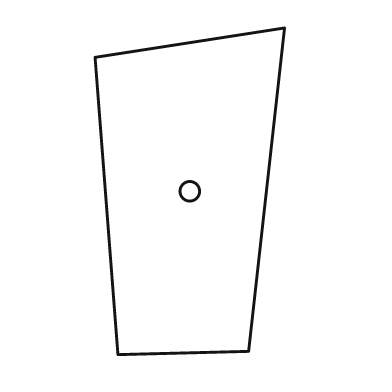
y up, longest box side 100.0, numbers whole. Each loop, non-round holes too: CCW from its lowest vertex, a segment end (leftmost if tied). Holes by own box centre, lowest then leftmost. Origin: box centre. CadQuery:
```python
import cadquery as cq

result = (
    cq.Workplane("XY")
    .moveTo(-22.0, -50.0)
    .lineTo(18.0, -49.0)
    .lineTo(29.0, 50.0)
    .lineTo(-29.0, 41.0)
    .close()
    .moveTo(0.0, 0.0)
    .circle(3.0)
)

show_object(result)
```